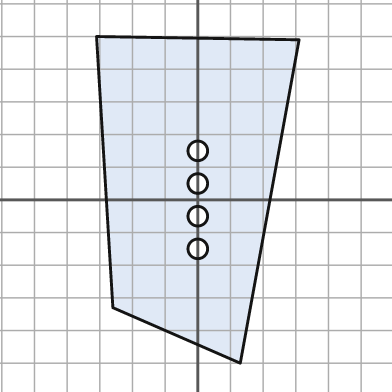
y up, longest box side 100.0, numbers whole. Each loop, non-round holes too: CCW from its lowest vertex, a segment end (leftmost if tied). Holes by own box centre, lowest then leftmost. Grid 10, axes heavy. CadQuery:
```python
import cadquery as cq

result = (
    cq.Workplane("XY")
    .moveTo(13.0, -50.0)
    .lineTo(31.0, 49.0)
    .lineTo(-31.0, 50.0)
    .lineTo(-26.0, -33.0)
    .close()
    .moveTo(0.0, -15.0)
    .circle(3.0)
    .moveTo(0.0, -5.0)
    .circle(3.0)
    .moveTo(0.0, 5.0)
    .circle(3.0)
    .moveTo(0.0, 15.0)
    .circle(3.0)
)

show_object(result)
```